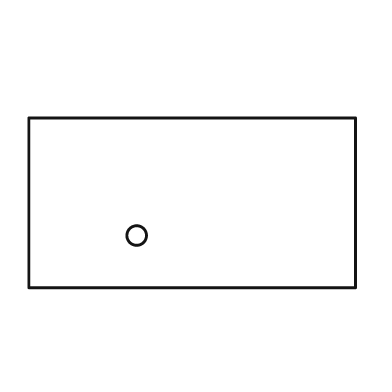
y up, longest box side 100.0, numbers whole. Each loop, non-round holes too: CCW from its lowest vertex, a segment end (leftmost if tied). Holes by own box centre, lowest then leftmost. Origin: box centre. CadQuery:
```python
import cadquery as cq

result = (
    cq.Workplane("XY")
    .moveTo(-50.0, -26.0)
    .lineTo(50.0, -26.0)
    .lineTo(50.0, 26.0)
    .lineTo(-50.0, 26.0)
    .close()
    .moveTo(-17.0, -10.0)
    .circle(3.0)
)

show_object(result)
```